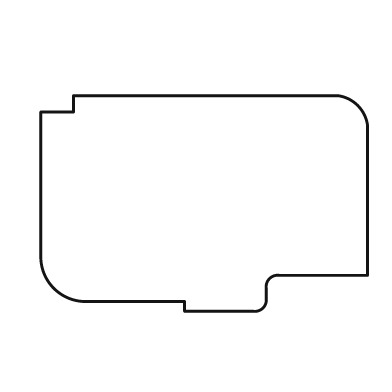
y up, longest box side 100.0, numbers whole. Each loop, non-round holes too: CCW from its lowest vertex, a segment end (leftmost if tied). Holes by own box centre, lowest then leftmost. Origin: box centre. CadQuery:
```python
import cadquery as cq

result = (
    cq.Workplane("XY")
    .moveTo(-6.0, -33.0)
    .lineTo(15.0, -33.0)
    .threePointArc((18.0, -32.0), (19.0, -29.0))
    .lineTo(19.0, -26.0)
    .threePointArc((20.0, -23.0), (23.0, -22.0))
    .lineTo(50.0, -22.0)
    .lineTo(50.0, 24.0)
    .threePointArc((47.0, 30.0), (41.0, 33.0))
    .lineTo(-40.0, 33.0)
    .lineTo(-40.0, 28.0)
    .lineTo(-50.0, 28.0)
    .lineTo(-50.0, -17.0)
    .threePointArc((-46.0, -26.0), (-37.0, -30.0))
    .lineTo(-6.0, -30.0)
    .close()
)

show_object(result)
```